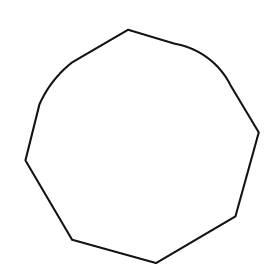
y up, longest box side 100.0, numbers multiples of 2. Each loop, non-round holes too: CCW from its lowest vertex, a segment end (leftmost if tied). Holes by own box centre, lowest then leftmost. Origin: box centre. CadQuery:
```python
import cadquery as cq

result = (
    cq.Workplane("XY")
    .moveTo(6.0, -50.0)
    .lineTo(40.0, -30.0)
    .lineTo(50.0, 6.0)
    .lineTo(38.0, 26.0)
    .threePointArc((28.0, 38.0), (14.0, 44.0))
    .lineTo(-6.0, 50.0)
    .lineTo(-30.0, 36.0)
    .threePointArc((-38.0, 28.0), (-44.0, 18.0))
    .lineTo(-50.0, -6.0)
    .lineTo(-30.0, -40.0)
    .close()
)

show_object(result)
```